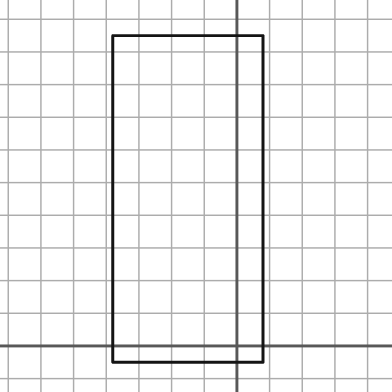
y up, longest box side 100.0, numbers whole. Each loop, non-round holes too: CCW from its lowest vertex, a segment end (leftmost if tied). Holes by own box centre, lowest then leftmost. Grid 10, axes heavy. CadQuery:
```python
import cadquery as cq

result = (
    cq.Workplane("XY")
    .moveTo(-38.0, -5.0)
    .lineTo(8.0, -5.0)
    .lineTo(8.0, 95.0)
    .lineTo(-38.0, 95.0)
    .close()
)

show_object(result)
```